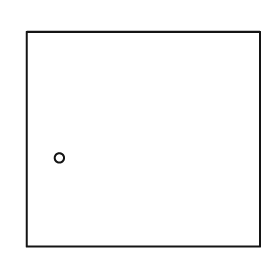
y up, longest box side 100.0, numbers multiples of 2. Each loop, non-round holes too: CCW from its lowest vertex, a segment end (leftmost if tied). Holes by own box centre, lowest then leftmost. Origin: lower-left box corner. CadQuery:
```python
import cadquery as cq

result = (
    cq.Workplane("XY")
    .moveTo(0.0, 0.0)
    .lineTo(100.0, 0.0)
    .lineTo(100.0, 92.0)
    .lineTo(0.0, 92.0)
    .close()
    .moveTo(14.0, 38.0)
    .circle(2.0)
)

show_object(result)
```